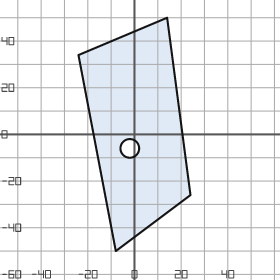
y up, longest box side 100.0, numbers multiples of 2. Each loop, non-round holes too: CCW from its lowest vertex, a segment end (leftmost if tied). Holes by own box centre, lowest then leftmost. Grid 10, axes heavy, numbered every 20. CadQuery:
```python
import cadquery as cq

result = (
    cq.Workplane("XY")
    .moveTo(-8.0, -50.0)
    .lineTo(24.0, -26.0)
    .lineTo(14.0, 50.0)
    .lineTo(-24.0, 34.0)
    .close()
    .moveTo(-2.0, -6.0)
    .circle(4.0)
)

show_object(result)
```